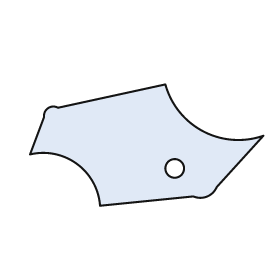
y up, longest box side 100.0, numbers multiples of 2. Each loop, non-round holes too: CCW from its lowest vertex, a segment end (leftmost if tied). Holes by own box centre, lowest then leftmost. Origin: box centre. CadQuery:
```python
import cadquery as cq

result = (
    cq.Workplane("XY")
    .moveTo(-20.0, -26.0)
    .lineTo(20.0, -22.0)
    .threePointArc((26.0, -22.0), (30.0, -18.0))
    .lineTo(50.0, 4.0)
    .threePointArc((24.0, 6.0), (8.0, 26.0))
    .lineTo(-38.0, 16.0)
    .threePointArc((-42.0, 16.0), (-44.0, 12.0))
    .lineTo(-50.0, -4.0)
    .threePointArc((-30.0, -8.0), (-20.0, -26.0))
    .close()
    .moveTo(12.0, -10.0)
    .circle(4.0)
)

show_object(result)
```